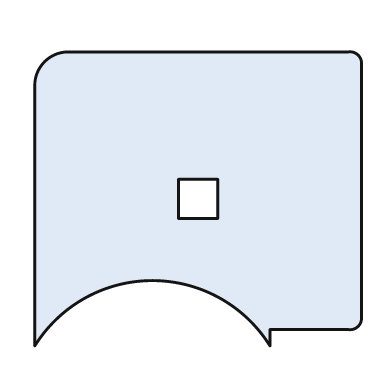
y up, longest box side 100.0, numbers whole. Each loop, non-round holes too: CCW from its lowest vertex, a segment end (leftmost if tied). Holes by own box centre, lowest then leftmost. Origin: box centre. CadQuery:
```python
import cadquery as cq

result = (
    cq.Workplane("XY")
    .moveTo(-50.0, -45.0)
    .threePointArc((-14.0, -25.0), (22.0, -45.0))
    .lineTo(22.0, -40.0)
    .lineTo(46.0, -40.0)
    .threePointArc((49.0, -39.0), (50.0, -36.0))
    .lineTo(50.0, 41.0)
    .threePointArc((49.0, 44.0), (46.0, 45.0))
    .lineTo(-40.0, 45.0)
    .threePointArc((-47.0, 42.0), (-50.0, 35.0))
    .close()
    .moveTo(-6.0, -6.0)
    .lineTo(6.0, -6.0)
    .lineTo(6.0, 6.0)
    .lineTo(-6.0, 6.0)
    .close()
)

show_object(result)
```